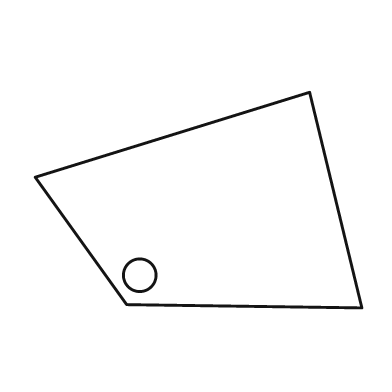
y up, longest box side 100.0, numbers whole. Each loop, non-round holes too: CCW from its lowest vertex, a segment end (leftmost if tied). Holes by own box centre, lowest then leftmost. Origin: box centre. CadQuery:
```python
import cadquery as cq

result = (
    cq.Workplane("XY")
    .moveTo(50.0, -33.0)
    .lineTo(34.0, 33.0)
    .lineTo(-50.0, 7.0)
    .lineTo(-22.0, -32.0)
    .close()
    .moveTo(-18.0, -23.0)
    .circle(5.0)
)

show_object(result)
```